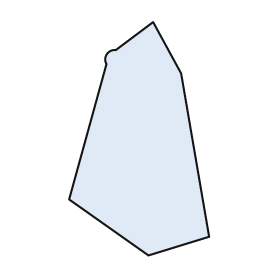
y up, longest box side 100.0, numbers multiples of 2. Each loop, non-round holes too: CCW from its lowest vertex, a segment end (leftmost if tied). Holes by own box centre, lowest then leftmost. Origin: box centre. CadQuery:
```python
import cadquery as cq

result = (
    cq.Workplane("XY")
    .moveTo(4.0, -50.0)
    .lineTo(30.0, -42.0)
    .lineTo(18.0, 28.0)
    .lineTo(6.0, 50.0)
    .lineTo(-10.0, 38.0)
    .threePointArc((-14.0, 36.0), (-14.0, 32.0))
    .lineTo(-30.0, -26.0)
    .close()
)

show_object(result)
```